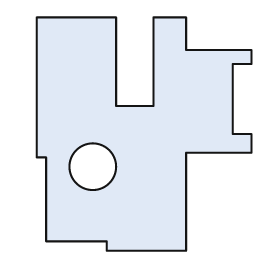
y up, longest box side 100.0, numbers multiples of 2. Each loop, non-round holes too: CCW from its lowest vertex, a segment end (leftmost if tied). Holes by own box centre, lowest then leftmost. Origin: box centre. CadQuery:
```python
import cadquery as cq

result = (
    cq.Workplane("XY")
    .moveTo(-16.0, -50.0)
    .lineTo(18.0, -50.0)
    .lineTo(18.0, -8.0)
    .lineTo(46.0, -8.0)
    .lineTo(46.0, 0.0)
    .lineTo(38.0, 0.0)
    .lineTo(38.0, 30.0)
    .lineTo(46.0, 30.0)
    .lineTo(46.0, 36.0)
    .lineTo(18.0, 36.0)
    .lineTo(18.0, 50.0)
    .lineTo(4.0, 50.0)
    .lineTo(4.0, 12.0)
    .lineTo(-12.0, 12.0)
    .lineTo(-12.0, 50.0)
    .lineTo(-46.0, 50.0)
    .lineTo(-46.0, -10.0)
    .lineTo(-42.0, -10.0)
    .lineTo(-42.0, -46.0)
    .lineTo(-16.0, -46.0)
    .close()
    .moveTo(-22.0, -14.0)
    .circle(10.0)
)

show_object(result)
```